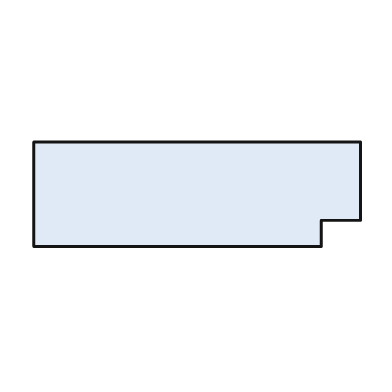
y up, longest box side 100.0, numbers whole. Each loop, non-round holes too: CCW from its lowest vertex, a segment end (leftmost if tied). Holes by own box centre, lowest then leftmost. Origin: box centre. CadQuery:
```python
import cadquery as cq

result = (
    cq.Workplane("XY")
    .moveTo(-50.0, -16.0)
    .lineTo(38.0, -16.0)
    .lineTo(38.0, -8.0)
    .lineTo(50.0, -8.0)
    .lineTo(50.0, 16.0)
    .lineTo(-50.0, 16.0)
    .close()
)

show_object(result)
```